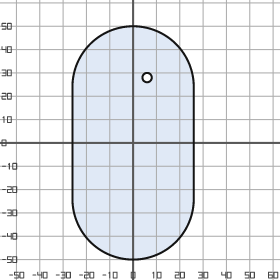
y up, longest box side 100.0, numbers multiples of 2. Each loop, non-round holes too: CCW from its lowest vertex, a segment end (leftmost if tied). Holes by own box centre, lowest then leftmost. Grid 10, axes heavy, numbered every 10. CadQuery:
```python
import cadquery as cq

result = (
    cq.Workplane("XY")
    .moveTo(-26.0, -24.0)
    .threePointArc((0.0, -50.0), (26.0, -24.0))
    .lineTo(26.0, 24.0)
    .threePointArc((0.0, 50.0), (-26.0, 24.0))
    .close()
    .moveTo(6.0, 28.0)
    .circle(2.0)
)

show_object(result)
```